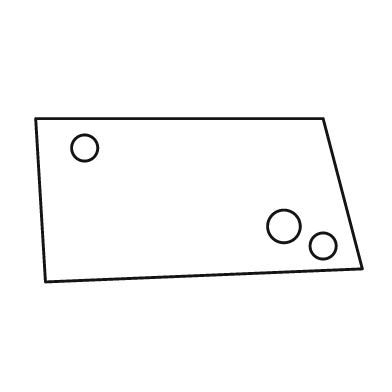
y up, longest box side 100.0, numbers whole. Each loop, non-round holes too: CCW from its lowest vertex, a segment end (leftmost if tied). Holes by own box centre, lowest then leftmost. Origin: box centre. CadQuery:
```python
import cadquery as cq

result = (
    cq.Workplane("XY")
    .moveTo(-47.0, -25.0)
    .lineTo(50.0, -21.0)
    .lineTo(38.0, 25.0)
    .lineTo(-50.0, 25.0)
    .close()
    .moveTo(38.0, -14.0)
    .circle(4.0)
    .moveTo(26.0, -8.0)
    .circle(5.0)
    .moveTo(-35.0, 16.0)
    .circle(4.0)
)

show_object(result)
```